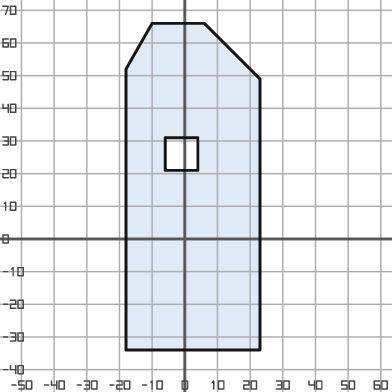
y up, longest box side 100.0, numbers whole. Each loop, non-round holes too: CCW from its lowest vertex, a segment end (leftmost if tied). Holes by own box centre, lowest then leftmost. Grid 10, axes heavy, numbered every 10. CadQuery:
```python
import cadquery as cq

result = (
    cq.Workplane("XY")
    .moveTo(-18.0, -34.0)
    .lineTo(23.0, -34.0)
    .lineTo(23.0, 49.0)
    .lineTo(6.0, 66.0)
    .lineTo(-10.0, 66.0)
    .lineTo(-18.0, 52.0)
    .close()
    .moveTo(-6.0, 21.0)
    .lineTo(4.0, 21.0)
    .lineTo(4.0, 31.0)
    .lineTo(-6.0, 31.0)
    .close()
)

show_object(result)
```